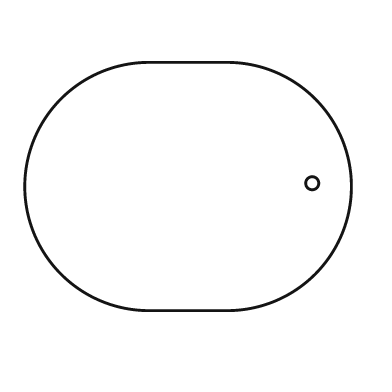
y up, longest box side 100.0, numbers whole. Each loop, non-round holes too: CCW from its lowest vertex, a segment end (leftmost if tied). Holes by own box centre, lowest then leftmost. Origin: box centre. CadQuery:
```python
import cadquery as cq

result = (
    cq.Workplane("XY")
    .moveTo(-12.0, -38.0)
    .lineTo(12.0, -38.0)
    .threePointArc((50.0, 0.0), (12.0, 38.0))
    .lineTo(-12.0, 38.0)
    .threePointArc((-50.0, 0.0), (-12.0, -38.0))
    .close()
    .moveTo(38.0, 1.0)
    .circle(2.0)
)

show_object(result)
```